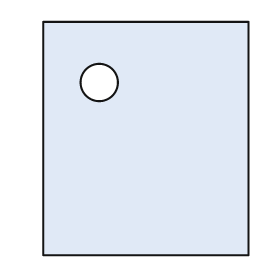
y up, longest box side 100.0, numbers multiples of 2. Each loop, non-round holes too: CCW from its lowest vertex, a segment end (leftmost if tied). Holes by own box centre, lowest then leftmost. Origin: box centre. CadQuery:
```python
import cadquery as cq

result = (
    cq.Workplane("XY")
    .moveTo(-44.0, -50.0)
    .lineTo(44.0, -50.0)
    .lineTo(44.0, 50.0)
    .lineTo(-44.0, 50.0)
    .close()
    .moveTo(-20.0, 24.0)
    .circle(8.0)
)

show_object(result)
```